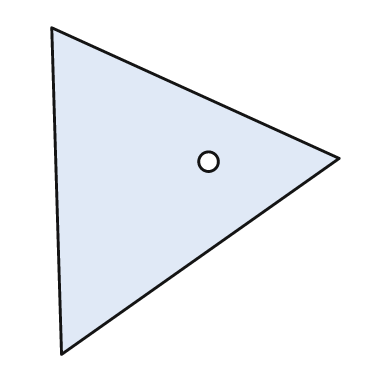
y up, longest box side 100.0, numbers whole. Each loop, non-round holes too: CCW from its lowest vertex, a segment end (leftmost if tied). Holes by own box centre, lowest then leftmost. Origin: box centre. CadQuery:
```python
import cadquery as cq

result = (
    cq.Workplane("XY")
    .moveTo(-41.0, -50.0)
    .lineTo(44.0, 10.0)
    .lineTo(-44.0, 50.0)
    .close()
    .moveTo(4.0, 9.0)
    .circle(3.0)
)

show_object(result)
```